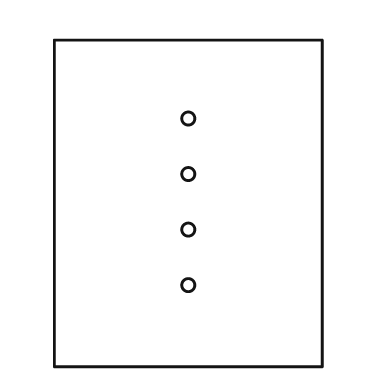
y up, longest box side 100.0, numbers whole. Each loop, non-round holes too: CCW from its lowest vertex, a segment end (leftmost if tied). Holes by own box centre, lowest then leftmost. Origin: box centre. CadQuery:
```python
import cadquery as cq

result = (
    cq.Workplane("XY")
    .moveTo(-41.0, -50.0)
    .lineTo(41.0, -50.0)
    .lineTo(41.0, 50.0)
    .lineTo(-41.0, 50.0)
    .close()
    .moveTo(0.0, -25.0)
    .circle(2.0)
    .moveTo(0.0, -8.0)
    .circle(2.0)
    .moveTo(0.0, 9.0)
    .circle(2.0)
    .moveTo(0.0, 26.0)
    .circle(2.0)
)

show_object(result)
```